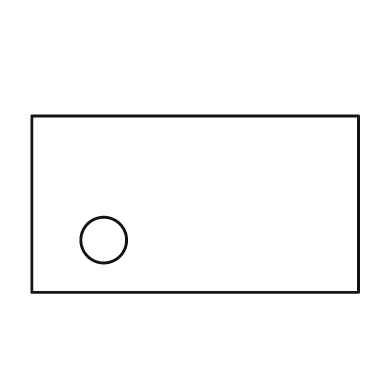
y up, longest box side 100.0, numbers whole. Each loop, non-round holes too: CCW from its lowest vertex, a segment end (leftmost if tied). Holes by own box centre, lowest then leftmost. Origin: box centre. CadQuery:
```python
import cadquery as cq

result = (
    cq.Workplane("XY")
    .moveTo(-50.0, -27.0)
    .lineTo(50.0, -27.0)
    .lineTo(50.0, 27.0)
    .lineTo(-50.0, 27.0)
    .close()
    .moveTo(-28.0, -11.0)
    .circle(7.0)
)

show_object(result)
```